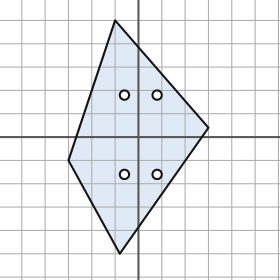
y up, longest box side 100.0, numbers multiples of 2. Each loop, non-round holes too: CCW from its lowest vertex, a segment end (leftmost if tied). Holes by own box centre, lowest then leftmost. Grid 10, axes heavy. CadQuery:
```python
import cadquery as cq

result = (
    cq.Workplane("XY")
    .moveTo(-8.0, -50.0)
    .lineTo(30.0, 4.0)
    .lineTo(-10.0, 50.0)
    .lineTo(-30.0, -10.0)
    .close()
    .moveTo(-6.0, -16.0)
    .circle(2.0)
    .moveTo(8.0, -16.0)
    .circle(2.0)
    .moveTo(-6.0, 18.0)
    .circle(2.0)
    .moveTo(8.0, 18.0)
    .circle(2.0)
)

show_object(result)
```